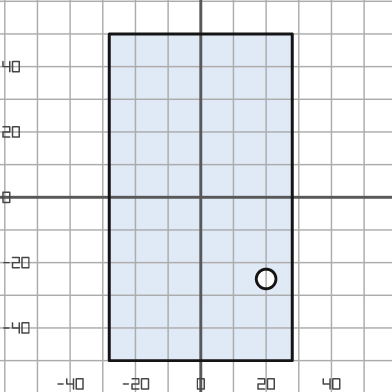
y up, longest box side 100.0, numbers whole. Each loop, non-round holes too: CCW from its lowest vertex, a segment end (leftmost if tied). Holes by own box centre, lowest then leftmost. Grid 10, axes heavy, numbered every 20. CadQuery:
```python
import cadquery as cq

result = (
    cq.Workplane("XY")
    .moveTo(-28.0, -50.0)
    .lineTo(28.0, -50.0)
    .lineTo(28.0, 50.0)
    .lineTo(-28.0, 50.0)
    .close()
    .moveTo(20.0, -25.0)
    .circle(3.0)
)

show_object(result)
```